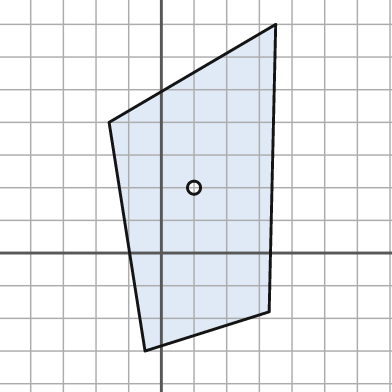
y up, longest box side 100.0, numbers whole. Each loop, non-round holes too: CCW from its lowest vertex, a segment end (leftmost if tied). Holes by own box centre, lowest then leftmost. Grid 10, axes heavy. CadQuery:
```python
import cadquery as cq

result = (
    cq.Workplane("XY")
    .moveTo(-5.0, -30.0)
    .lineTo(33.0, -18.0)
    .lineTo(35.0, 70.0)
    .lineTo(-16.0, 40.0)
    .close()
    .moveTo(10.0, 20.0)
    .circle(2.0)
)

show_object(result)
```